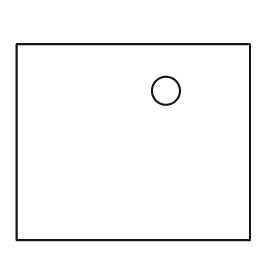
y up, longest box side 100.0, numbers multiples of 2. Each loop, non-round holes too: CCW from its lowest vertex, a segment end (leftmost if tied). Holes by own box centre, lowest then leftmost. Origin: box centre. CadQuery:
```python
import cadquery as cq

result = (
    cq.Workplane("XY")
    .moveTo(-50.0, -42.0)
    .lineTo(50.0, -42.0)
    .lineTo(50.0, 42.0)
    .lineTo(-50.0, 42.0)
    .close()
    .moveTo(14.0, 22.0)
    .circle(6.0)
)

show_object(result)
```